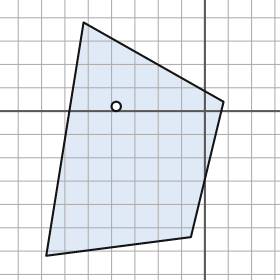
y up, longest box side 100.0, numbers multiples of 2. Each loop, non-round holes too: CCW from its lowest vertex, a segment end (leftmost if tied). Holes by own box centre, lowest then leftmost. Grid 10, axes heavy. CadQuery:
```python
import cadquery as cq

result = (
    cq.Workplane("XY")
    .moveTo(-68.0, -62.0)
    .lineTo(-6.0, -54.0)
    .lineTo(8.0, 4.0)
    .lineTo(-52.0, 38.0)
    .close()
    .moveTo(-38.0, 2.0)
    .circle(2.0)
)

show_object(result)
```